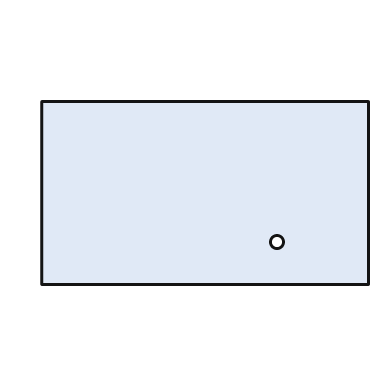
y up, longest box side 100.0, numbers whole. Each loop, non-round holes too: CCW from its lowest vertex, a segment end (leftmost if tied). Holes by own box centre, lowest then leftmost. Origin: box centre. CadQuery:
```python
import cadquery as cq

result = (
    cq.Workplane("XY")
    .moveTo(-50.0, -28.0)
    .lineTo(50.0, -28.0)
    .lineTo(50.0, 28.0)
    .lineTo(-50.0, 28.0)
    .close()
    .moveTo(22.0, -15.0)
    .circle(2.0)
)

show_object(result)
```